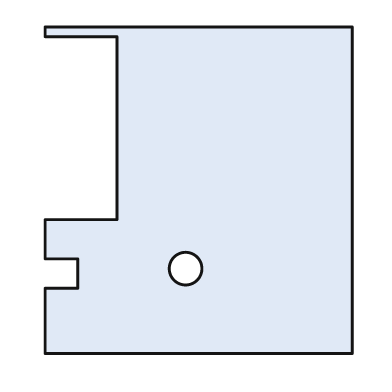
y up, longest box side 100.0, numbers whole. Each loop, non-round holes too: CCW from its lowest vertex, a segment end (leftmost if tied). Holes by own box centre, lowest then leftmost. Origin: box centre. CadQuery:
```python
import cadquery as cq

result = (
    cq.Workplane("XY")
    .moveTo(-47.0, -50.0)
    .lineTo(47.0, -50.0)
    .lineTo(47.0, 50.0)
    .lineTo(-47.0, 50.0)
    .lineTo(-47.0, 47.0)
    .lineTo(-25.0, 47.0)
    .lineTo(-25.0, -9.0)
    .lineTo(-47.0, -9.0)
    .lineTo(-47.0, -21.0)
    .lineTo(-37.0, -21.0)
    .lineTo(-37.0, -30.0)
    .lineTo(-47.0, -30.0)
    .close()
    .moveTo(-4.0, -24.0)
    .circle(5.0)
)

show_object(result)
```